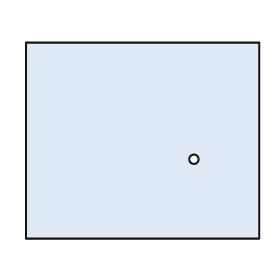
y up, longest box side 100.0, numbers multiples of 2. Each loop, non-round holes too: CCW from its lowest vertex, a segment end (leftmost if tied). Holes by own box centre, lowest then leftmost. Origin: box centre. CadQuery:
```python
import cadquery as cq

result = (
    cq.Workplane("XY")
    .moveTo(-50.0, -42.0)
    .lineTo(50.0, -42.0)
    .lineTo(50.0, 42.0)
    .lineTo(-50.0, 42.0)
    .close()
    .moveTo(22.0, -8.0)
    .circle(2.0)
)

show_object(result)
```